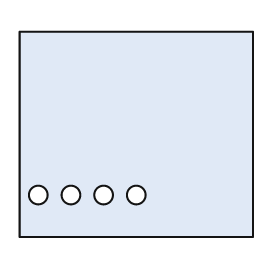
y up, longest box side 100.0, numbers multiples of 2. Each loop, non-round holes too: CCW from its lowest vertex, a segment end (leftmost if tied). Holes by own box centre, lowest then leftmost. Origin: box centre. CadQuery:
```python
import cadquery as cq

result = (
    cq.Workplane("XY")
    .moveTo(-50.0, -44.0)
    .lineTo(50.0, -44.0)
    .lineTo(50.0, 44.0)
    .lineTo(-50.0, 44.0)
    .close()
    .moveTo(-42.0, -26.0)
    .circle(4.0)
    .moveTo(-28.0, -26.0)
    .circle(4.0)
    .moveTo(-14.0, -26.0)
    .circle(4.0)
    .moveTo(0.0, -26.0)
    .circle(4.0)
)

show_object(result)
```